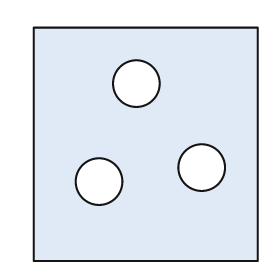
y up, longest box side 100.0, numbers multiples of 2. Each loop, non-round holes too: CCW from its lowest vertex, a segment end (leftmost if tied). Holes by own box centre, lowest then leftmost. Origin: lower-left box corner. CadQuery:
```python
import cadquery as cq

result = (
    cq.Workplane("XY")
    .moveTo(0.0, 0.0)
    .lineTo(96.0, 0.0)
    .lineTo(96.0, 100.0)
    .lineTo(0.0, 100.0)
    .close()
    .moveTo(28.0, 34.0)
    .circle(10.0)
    .moveTo(72.0, 40.0)
    .circle(10.0)
    .moveTo(44.0, 76.0)
    .circle(10.0)
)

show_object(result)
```